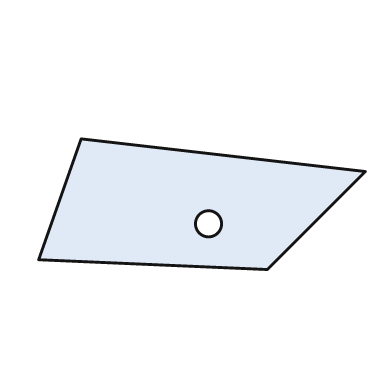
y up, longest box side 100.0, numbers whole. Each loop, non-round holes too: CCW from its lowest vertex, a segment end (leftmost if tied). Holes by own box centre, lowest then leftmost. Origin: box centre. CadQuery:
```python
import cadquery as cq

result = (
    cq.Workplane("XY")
    .moveTo(20.0, -20.0)
    .lineTo(50.0, 10.0)
    .lineTo(-37.0, 20.0)
    .lineTo(-50.0, -17.0)
    .close()
    .moveTo(2.0, -6.0)
    .circle(4.0)
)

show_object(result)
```